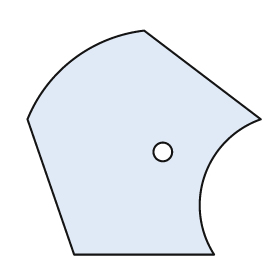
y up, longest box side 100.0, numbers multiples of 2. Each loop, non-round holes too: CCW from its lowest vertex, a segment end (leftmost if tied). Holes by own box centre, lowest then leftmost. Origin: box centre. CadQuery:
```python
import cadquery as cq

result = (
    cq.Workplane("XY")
    .moveTo(-30.0, -48.0)
    .lineTo(30.0, -48.0)
    .threePointArc((26.0, -14.0), (50.0, 10.0))
    .lineTo(0.0, 48.0)
    .threePointArc((-30.0, 36.0), (-50.0, 10.0))
    .close()
    .moveTo(8.0, -4.0)
    .circle(4.0)
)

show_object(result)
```